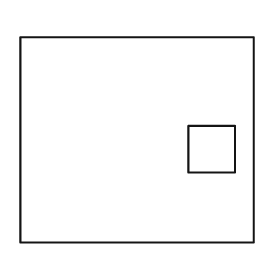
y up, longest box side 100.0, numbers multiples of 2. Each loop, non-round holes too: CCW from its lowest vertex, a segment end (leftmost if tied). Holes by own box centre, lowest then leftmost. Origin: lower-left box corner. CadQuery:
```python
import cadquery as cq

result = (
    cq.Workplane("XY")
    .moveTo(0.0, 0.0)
    .lineTo(100.0, 0.0)
    .lineTo(100.0, 88.0)
    .lineTo(0.0, 88.0)
    .close()
    .moveTo(72.0, 30.0)
    .lineTo(92.0, 30.0)
    .lineTo(92.0, 50.0)
    .lineTo(72.0, 50.0)
    .close()
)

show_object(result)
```